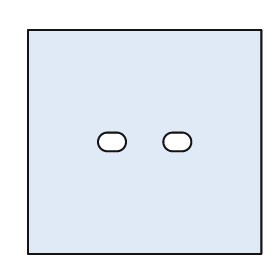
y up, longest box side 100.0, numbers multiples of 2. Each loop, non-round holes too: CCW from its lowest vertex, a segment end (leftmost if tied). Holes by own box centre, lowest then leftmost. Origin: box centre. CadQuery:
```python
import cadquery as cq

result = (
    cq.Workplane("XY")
    .moveTo(-50.0, -48.0)
    .lineTo(50.0, -48.0)
    .lineTo(50.0, 48.0)
    .lineTo(-50.0, 48.0)
    .close()
    .moveTo(-16.0, -4.0)
    .lineTo(-12.0, -4.0)
    .threePointArc((-8.0, 0.0), (-12.0, 4.0))
    .lineTo(-16.0, 4.0)
    .threePointArc((-20.0, 0.0), (-16.0, -4.0))
    .close()
    .moveTo(12.0, -4.0)
    .lineTo(16.0, -4.0)
    .threePointArc((20.0, 0.0), (16.0, 4.0))
    .lineTo(12.0, 4.0)
    .threePointArc((8.0, 0.0), (12.0, -4.0))
    .close()
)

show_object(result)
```